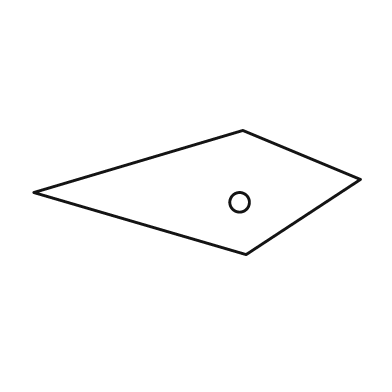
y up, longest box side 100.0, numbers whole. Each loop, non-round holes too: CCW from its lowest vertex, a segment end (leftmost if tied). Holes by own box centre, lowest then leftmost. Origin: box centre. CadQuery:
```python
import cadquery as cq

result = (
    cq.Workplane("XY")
    .moveTo(15.0, -19.0)
    .lineTo(50.0, 4.0)
    .lineTo(14.0, 19.0)
    .lineTo(-50.0, 0.0)
    .close()
    .moveTo(13.0, -3.0)
    .circle(3.0)
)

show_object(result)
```